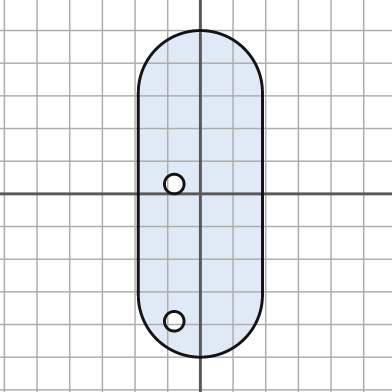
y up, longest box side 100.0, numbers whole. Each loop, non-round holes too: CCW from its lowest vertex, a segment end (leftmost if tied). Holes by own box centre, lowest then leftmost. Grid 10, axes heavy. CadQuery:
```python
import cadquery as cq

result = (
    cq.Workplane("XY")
    .moveTo(-19.0, -31.0)
    .threePointArc((0.0, -50.0), (19.0, -31.0))
    .lineTo(19.0, 31.0)
    .threePointArc((0.0, 50.0), (-19.0, 31.0))
    .close()
    .moveTo(-8.0, -39.0)
    .circle(3.0)
    .moveTo(-8.0, 3.0)
    .circle(3.0)
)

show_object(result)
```